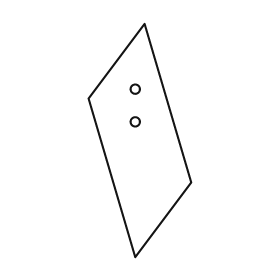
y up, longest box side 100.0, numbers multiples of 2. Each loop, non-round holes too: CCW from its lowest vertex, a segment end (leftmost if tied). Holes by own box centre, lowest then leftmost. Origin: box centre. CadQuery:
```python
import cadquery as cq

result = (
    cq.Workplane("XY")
    .moveTo(-2.0, -50.0)
    .lineTo(22.0, -18.0)
    .lineTo(2.0, 50.0)
    .lineTo(-22.0, 18.0)
    .close()
    .moveTo(-2.0, 8.0)
    .circle(2.0)
    .moveTo(-2.0, 22.0)
    .circle(2.0)
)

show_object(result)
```